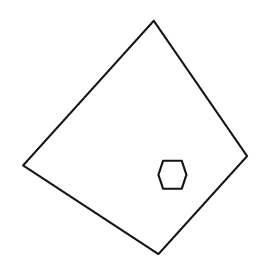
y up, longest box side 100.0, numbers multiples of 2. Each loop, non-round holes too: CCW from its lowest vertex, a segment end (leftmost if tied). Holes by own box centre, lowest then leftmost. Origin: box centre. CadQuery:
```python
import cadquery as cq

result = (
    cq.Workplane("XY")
    .moveTo(10.0, -50.0)
    .lineTo(48.0, -8.0)
    .lineTo(8.0, 50.0)
    .lineTo(-48.0, -12.0)
    .close()
    .moveTo(12.0, -22.0)
    .lineTo(20.0, -22.0)
    .lineTo(22.0, -16.0)
    .lineTo(20.0, -10.0)
    .lineTo(12.0, -10.0)
    .lineTo(10.0, -16.0)
    .close()
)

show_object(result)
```